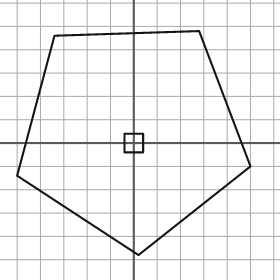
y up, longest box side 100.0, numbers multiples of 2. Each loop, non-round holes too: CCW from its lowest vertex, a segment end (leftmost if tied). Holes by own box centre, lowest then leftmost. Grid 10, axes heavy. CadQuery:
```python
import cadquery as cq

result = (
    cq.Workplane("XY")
    .moveTo(2.0, -48.0)
    .lineTo(50.0, -10.0)
    .lineTo(28.0, 48.0)
    .lineTo(-34.0, 46.0)
    .lineTo(-50.0, -14.0)
    .close()
    .moveTo(-4.0, -4.0)
    .lineTo(4.0, -4.0)
    .lineTo(4.0, 4.0)
    .lineTo(-4.0, 4.0)
    .close()
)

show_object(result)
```